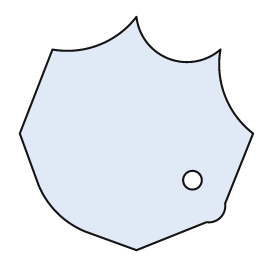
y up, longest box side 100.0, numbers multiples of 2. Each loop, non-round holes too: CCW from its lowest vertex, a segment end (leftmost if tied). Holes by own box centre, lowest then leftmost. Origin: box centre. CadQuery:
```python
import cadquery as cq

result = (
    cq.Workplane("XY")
    .moveTo(0.0, -50.0)
    .lineTo(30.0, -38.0)
    .threePointArc((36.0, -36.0), (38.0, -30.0))
    .lineTo(50.0, 0.0)
    .threePointArc((38.0, 16.0), (36.0, 36.0))
    .threePointArc((14.0, 32.0), (0.0, 50.0))
    .threePointArc((-16.0, 38.0), (-36.0, 36.0))
    .lineTo(-50.0, 0.0)
    .lineTo(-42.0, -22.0)
    .threePointArc((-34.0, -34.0), (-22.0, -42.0))
    .close()
    .moveTo(24.0, -20.0)
    .circle(4.0)
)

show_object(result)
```